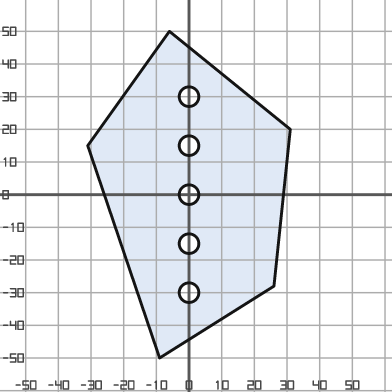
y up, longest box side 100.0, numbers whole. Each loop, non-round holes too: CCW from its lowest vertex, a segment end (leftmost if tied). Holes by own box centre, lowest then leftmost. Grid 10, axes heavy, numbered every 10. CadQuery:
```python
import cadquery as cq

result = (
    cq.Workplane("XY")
    .moveTo(-9.0, -50.0)
    .lineTo(26.0, -28.0)
    .lineTo(31.0, 20.0)
    .lineTo(-6.0, 50.0)
    .lineTo(-31.0, 15.0)
    .close()
    .moveTo(0.0, -30.0)
    .circle(3.0)
    .moveTo(0.0, -15.0)
    .circle(3.0)
    .moveTo(0.0, 0.0)
    .circle(3.0)
    .moveTo(0.0, 15.0)
    .circle(3.0)
    .moveTo(0.0, 30.0)
    .circle(3.0)
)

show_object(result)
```